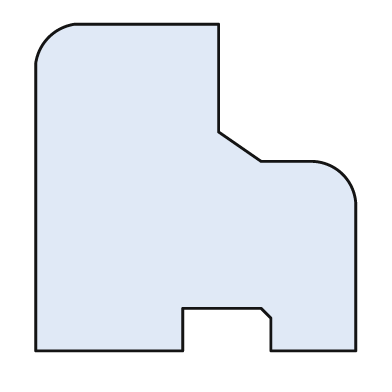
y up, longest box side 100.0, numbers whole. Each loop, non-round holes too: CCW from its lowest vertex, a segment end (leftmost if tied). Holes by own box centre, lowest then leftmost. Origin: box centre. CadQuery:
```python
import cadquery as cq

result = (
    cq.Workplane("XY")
    .moveTo(-49.0, -50.0)
    .lineTo(-4.0, -50.0)
    .lineTo(-4.0, -37.0)
    .lineTo(20.0, -37.0)
    .lineTo(23.0, -40.0)
    .lineTo(23.0, -50.0)
    .lineTo(49.0, -50.0)
    .lineTo(49.0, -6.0)
    .threePointArc((45.0, 4.0), (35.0, 8.0))
    .lineTo(20.0, 8.0)
    .lineTo(7.0, 17.0)
    .lineTo(7.0, 50.0)
    .lineTo(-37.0, 50.0)
    .threePointArc((-45.0, 46.0), (-49.0, 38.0))
    .close()
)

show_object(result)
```